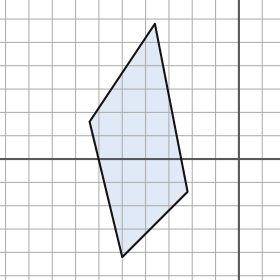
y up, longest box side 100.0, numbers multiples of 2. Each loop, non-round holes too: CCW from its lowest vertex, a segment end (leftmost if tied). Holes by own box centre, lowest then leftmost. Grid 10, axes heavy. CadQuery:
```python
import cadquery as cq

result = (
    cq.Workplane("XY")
    .moveTo(-50.0, -42.0)
    .lineTo(-22.0, -14.0)
    .lineTo(-36.0, 58.0)
    .lineTo(-64.0, 16.0)
    .close()
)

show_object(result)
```